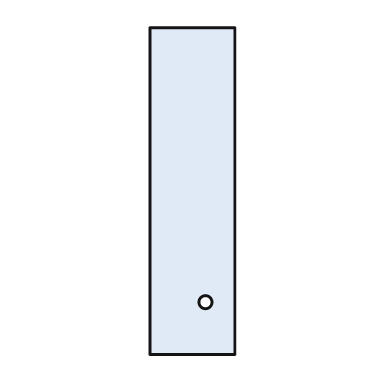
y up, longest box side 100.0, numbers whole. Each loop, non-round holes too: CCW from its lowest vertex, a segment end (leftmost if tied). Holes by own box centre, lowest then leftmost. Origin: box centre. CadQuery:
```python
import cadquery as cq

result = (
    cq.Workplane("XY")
    .moveTo(-13.0, -50.0)
    .lineTo(13.0, -50.0)
    .lineTo(13.0, 50.0)
    .lineTo(-13.0, 50.0)
    .close()
    .moveTo(4.0, -34.0)
    .circle(2.0)
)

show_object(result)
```